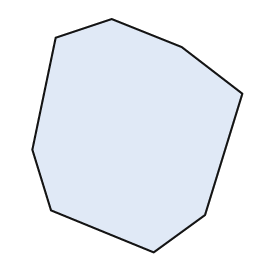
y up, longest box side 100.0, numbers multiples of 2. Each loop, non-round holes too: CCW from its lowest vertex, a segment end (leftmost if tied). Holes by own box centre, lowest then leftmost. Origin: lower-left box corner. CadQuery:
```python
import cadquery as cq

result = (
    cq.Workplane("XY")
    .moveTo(52.0, 0.0)
    .lineTo(74.0, 16.0)
    .lineTo(90.0, 68.0)
    .lineTo(64.0, 88.0)
    .lineTo(34.0, 100.0)
    .lineTo(10.0, 92.0)
    .lineTo(0.0, 44.0)
    .lineTo(8.0, 18.0)
    .close()
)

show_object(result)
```